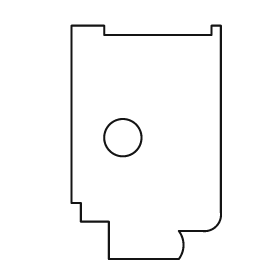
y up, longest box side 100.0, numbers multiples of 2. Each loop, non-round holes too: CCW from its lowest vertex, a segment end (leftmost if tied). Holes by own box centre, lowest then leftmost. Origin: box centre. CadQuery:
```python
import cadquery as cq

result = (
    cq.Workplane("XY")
    .moveTo(-16.0, -50.0)
    .lineTo(14.0, -50.0)
    .threePointArc((16.0, -44.0), (14.0, -38.0))
    .lineTo(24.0, -38.0)
    .threePointArc((30.0, -36.0), (32.0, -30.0))
    .lineTo(32.0, 50.0)
    .lineTo(28.0, 50.0)
    .lineTo(28.0, 46.0)
    .lineTo(-18.0, 46.0)
    .lineTo(-18.0, 50.0)
    .lineTo(-32.0, 50.0)
    .lineTo(-32.0, -26.0)
    .lineTo(-28.0, -26.0)
    .lineTo(-28.0, -34.0)
    .lineTo(-16.0, -34.0)
    .close()
    .moveTo(-10.0, 2.0)
    .circle(8.0)
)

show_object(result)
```